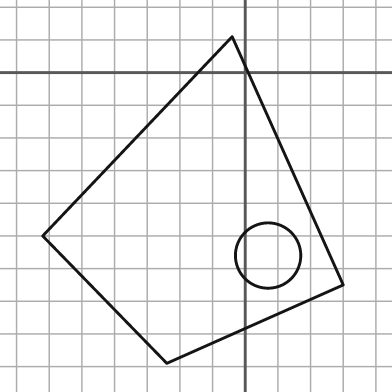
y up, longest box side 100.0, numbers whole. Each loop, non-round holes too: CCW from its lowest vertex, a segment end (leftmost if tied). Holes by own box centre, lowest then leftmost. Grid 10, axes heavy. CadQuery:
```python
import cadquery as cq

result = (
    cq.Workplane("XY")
    .moveTo(-24.0, -89.0)
    .lineTo(30.0, -65.0)
    .lineTo(-4.0, 11.0)
    .lineTo(-62.0, -50.0)
    .close()
    .moveTo(7.0, -56.0)
    .circle(10.0)
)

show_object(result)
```